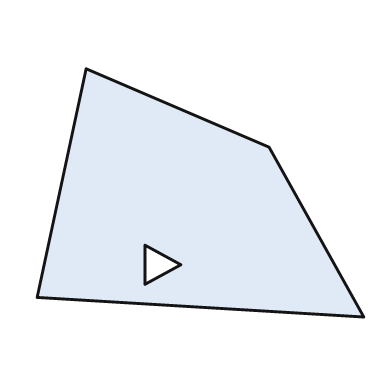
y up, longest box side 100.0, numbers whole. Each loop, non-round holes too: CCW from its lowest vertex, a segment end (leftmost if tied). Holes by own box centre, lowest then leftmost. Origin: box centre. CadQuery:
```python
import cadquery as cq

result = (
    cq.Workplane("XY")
    .moveTo(50.0, -38.0)
    .lineTo(21.0, 14.0)
    .lineTo(-35.0, 38.0)
    .lineTo(-50.0, -32.0)
    .close()
    .moveTo(-17.0, -28.0)
    .lineTo(-6.0, -22.0)
    .lineTo(-17.0, -16.0)
    .close()
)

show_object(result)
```